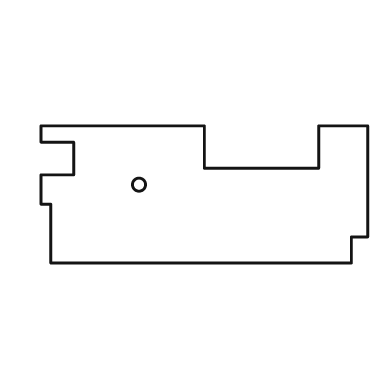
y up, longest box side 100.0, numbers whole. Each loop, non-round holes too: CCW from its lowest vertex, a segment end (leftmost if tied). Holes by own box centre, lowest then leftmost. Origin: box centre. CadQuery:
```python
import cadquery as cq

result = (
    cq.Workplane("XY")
    .moveTo(-47.0, -21.0)
    .lineTo(45.0, -21.0)
    .lineTo(45.0, -13.0)
    .lineTo(50.0, -13.0)
    .lineTo(50.0, 21.0)
    .lineTo(35.0, 21.0)
    .lineTo(35.0, 8.0)
    .lineTo(0.0, 8.0)
    .lineTo(0.0, 21.0)
    .lineTo(-50.0, 21.0)
    .lineTo(-50.0, 16.0)
    .lineTo(-40.0, 16.0)
    .lineTo(-40.0, 6.0)
    .lineTo(-50.0, 6.0)
    .lineTo(-50.0, -3.0)
    .lineTo(-47.0, -3.0)
    .close()
    .moveTo(-20.0, 3.0)
    .circle(2.0)
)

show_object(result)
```